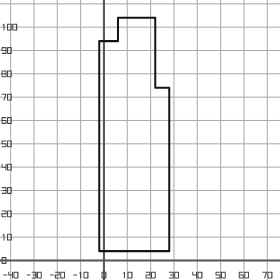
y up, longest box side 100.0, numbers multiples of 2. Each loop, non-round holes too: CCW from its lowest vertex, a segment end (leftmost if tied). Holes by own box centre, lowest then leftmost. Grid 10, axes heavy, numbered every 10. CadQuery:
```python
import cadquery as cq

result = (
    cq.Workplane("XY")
    .moveTo(-2.0, 4.0)
    .lineTo(28.0, 4.0)
    .lineTo(28.0, 74.0)
    .lineTo(22.0, 74.0)
    .lineTo(22.0, 104.0)
    .lineTo(6.0, 104.0)
    .lineTo(6.0, 94.0)
    .lineTo(-2.0, 94.0)
    .close()
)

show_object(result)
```